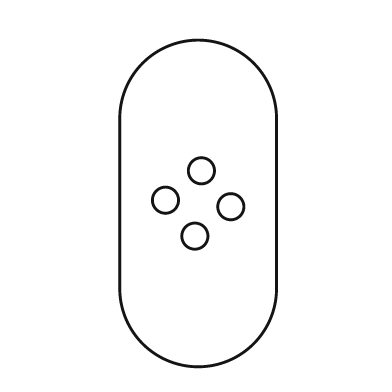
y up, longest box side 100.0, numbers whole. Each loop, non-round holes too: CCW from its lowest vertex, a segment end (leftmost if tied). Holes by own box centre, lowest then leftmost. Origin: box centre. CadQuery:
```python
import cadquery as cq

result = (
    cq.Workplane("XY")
    .moveTo(-24.0, -26.0)
    .threePointArc((0.0, -50.0), (24.0, -26.0))
    .lineTo(24.0, 26.0)
    .threePointArc((0.0, 50.0), (-24.0, 26.0))
    .close()
    .moveTo(-1.0, -10.0)
    .circle(4.0)
    .moveTo(10.0, -1.0)
    .circle(4.0)
    .moveTo(-10.0, 1.0)
    .circle(4.0)
    .moveTo(1.0, 10.0)
    .circle(4.0)
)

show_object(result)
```